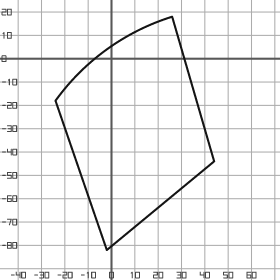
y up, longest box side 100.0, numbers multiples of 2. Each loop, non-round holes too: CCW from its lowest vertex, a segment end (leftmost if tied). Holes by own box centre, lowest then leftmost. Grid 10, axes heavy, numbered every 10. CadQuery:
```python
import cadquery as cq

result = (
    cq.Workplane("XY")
    .moveTo(-2.0, -82.0)
    .lineTo(44.0, -44.0)
    .lineTo(26.0, 18.0)
    .threePointArc((-2.0, 4.0), (-24.0, -18.0))
    .close()
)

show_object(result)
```